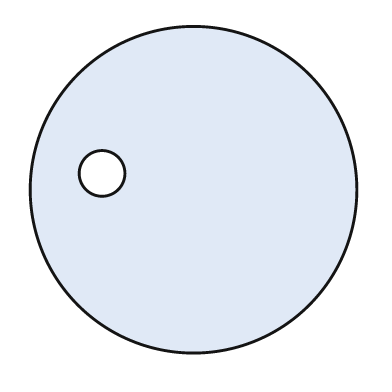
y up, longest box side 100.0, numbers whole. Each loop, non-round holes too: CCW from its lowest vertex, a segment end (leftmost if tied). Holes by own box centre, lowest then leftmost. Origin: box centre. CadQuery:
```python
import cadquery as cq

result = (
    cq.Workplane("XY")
    .moveTo(0.0, 0.0)
    .circle(50.0)
    .moveTo(-28.0, 5.0)
    .circle(7.0)
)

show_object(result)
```